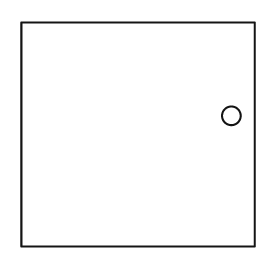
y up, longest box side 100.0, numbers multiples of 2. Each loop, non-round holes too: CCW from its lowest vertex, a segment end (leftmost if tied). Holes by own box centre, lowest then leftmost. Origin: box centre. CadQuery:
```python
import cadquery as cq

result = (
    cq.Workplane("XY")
    .moveTo(-50.0, -48.0)
    .lineTo(50.0, -48.0)
    .lineTo(50.0, 48.0)
    .lineTo(-50.0, 48.0)
    .close()
    .moveTo(40.0, 8.0)
    .circle(4.0)
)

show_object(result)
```